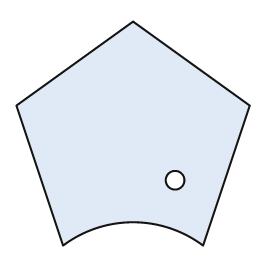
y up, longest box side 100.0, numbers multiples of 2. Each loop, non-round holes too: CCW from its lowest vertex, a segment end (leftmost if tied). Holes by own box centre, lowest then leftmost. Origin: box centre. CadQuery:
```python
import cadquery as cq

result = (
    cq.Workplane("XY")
    .moveTo(-30.0, -48.0)
    .threePointArc((0.0, -38.0), (30.0, -48.0))
    .lineTo(50.0, 12.0)
    .lineTo(0.0, 48.0)
    .lineTo(-50.0, 12.0)
    .close()
    .moveTo(18.0, -20.0)
    .circle(4.0)
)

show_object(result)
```